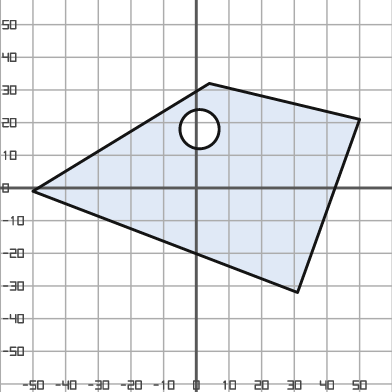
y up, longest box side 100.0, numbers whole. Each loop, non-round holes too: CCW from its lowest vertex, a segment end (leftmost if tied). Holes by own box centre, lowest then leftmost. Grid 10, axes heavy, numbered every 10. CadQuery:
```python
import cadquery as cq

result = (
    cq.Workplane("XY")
    .moveTo(31.0, -32.0)
    .lineTo(50.0, 21.0)
    .lineTo(4.0, 32.0)
    .lineTo(-50.0, -1.0)
    .close()
    .moveTo(1.0, 18.0)
    .circle(6.0)
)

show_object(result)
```